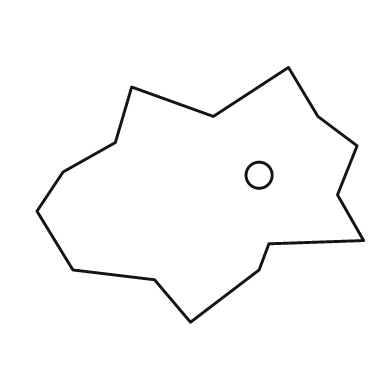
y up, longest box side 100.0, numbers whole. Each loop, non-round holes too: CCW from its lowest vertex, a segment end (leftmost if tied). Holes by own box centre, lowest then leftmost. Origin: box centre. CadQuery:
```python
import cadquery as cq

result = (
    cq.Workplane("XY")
    .moveTo(-3.0, -39.0)
    .lineTo(18.0, -23.0)
    .lineTo(21.0, -15.0)
    .lineTo(50.0, -14.0)
    .lineTo(42.0, 0.0)
    .lineTo(48.0, 15.0)
    .lineTo(36.0, 24.0)
    .lineTo(27.0, 39.0)
    .lineTo(4.0, 24.0)
    .lineTo(-21.0, 33.0)
    .lineTo(-26.0, 16.0)
    .lineTo(-42.0, 7.0)
    .lineTo(-50.0, -5.0)
    .lineTo(-39.0, -23.0)
    .lineTo(-14.0, -26.0)
    .close()
    .moveTo(18.0, 6.0)
    .circle(4.0)
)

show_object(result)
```